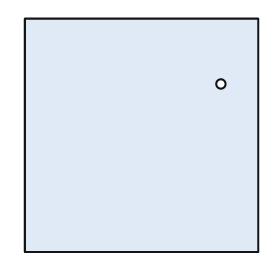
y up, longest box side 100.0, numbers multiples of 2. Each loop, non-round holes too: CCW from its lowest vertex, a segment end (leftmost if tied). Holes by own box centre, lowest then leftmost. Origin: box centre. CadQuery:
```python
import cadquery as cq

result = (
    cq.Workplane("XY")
    .moveTo(-50.0, -50.0)
    .lineTo(50.0, -50.0)
    .lineTo(50.0, 50.0)
    .lineTo(-50.0, 50.0)
    .close()
    .moveTo(34.0, 22.0)
    .circle(2.0)
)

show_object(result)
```